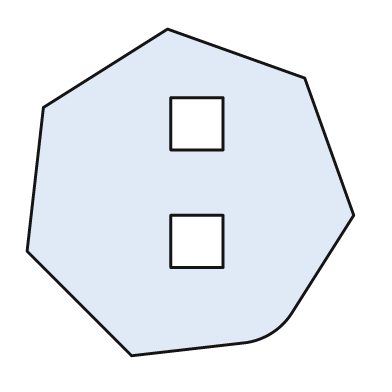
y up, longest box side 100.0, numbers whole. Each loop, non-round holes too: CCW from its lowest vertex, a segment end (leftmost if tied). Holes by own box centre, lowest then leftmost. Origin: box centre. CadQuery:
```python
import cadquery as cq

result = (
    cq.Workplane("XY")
    .moveTo(-18.0, -50.0)
    .lineTo(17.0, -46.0)
    .threePointArc((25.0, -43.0), (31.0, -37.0))
    .lineTo(50.0, -7.0)
    .lineTo(35.0, 35.0)
    .lineTo(-7.0, 50.0)
    .lineTo(-45.0, 26.0)
    .lineTo(-50.0, -18.0)
    .close()
    .moveTo(-6.0, -23.0)
    .lineTo(10.0, -23.0)
    .lineTo(10.0, -7.0)
    .lineTo(-6.0, -7.0)
    .close()
    .moveTo(-6.0, 13.0)
    .lineTo(10.0, 13.0)
    .lineTo(10.0, 29.0)
    .lineTo(-6.0, 29.0)
    .close()
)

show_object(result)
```